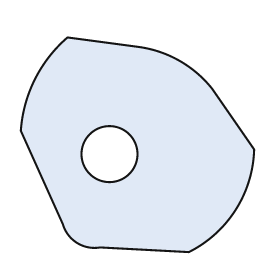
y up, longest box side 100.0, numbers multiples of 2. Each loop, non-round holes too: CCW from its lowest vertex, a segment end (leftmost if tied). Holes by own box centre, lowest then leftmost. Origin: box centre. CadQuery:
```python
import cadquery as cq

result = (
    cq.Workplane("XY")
    .moveTo(22.0, -46.0)
    .threePointArc((42.0, -28.0), (50.0, -2.0))
    .lineTo(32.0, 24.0)
    .threePointArc((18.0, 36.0), (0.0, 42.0))
    .lineTo(-30.0, 46.0)
    .threePointArc((-44.0, 28.0), (-50.0, 6.0))
    .lineTo(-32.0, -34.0)
    .threePointArc((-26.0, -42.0), (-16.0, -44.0))
    .close()
    .moveTo(-12.0, -4.0)
    .circle(12.0)
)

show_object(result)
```